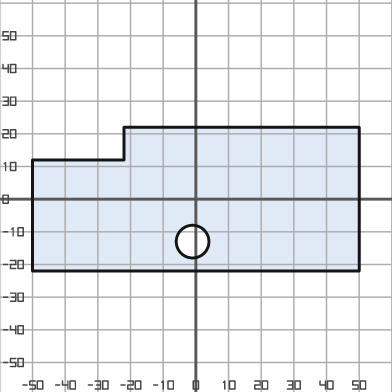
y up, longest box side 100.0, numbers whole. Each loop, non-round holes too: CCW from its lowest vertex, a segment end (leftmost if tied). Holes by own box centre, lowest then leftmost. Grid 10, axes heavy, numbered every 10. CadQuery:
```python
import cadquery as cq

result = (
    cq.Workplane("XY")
    .moveTo(-50.0, -22.0)
    .lineTo(50.0, -22.0)
    .lineTo(50.0, 22.0)
    .lineTo(-22.0, 22.0)
    .lineTo(-22.0, 12.0)
    .lineTo(-50.0, 12.0)
    .close()
    .moveTo(-1.0, -13.0)
    .circle(5.0)
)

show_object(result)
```